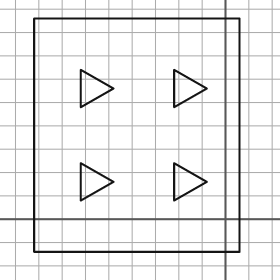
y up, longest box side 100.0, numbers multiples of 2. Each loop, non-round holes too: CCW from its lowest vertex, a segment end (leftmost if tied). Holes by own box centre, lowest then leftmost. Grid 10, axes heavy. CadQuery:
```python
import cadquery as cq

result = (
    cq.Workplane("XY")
    .moveTo(-82.0, -14.0)
    .lineTo(6.0, -14.0)
    .lineTo(6.0, 86.0)
    .lineTo(-82.0, 86.0)
    .close()
    .moveTo(-62.0, 8.0)
    .lineTo(-48.0, 16.0)
    .lineTo(-62.0, 24.0)
    .close()
    .moveTo(-22.0, 8.0)
    .lineTo(-8.0, 16.0)
    .lineTo(-22.0, 24.0)
    .close()
    .moveTo(-62.0, 48.0)
    .lineTo(-48.0, 56.0)
    .lineTo(-62.0, 64.0)
    .close()
    .moveTo(-22.0, 48.0)
    .lineTo(-8.0, 56.0)
    .lineTo(-22.0, 64.0)
    .close()
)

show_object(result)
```